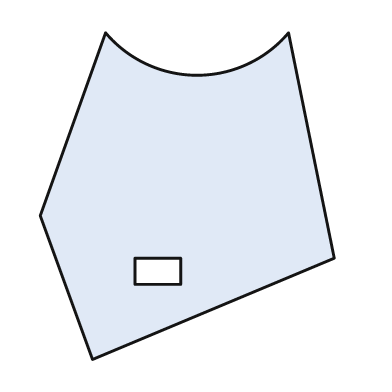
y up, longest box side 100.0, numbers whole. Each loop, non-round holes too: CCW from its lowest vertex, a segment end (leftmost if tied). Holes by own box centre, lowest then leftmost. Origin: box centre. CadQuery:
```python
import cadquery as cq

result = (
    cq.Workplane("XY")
    .moveTo(-29.0, -50.0)
    .lineTo(45.0, -19.0)
    .lineTo(31.0, 50.0)
    .threePointArc((3.0, 37.0), (-25.0, 50.0))
    .lineTo(-45.0, -6.0)
    .close()
    .moveTo(-16.0, -27.0)
    .lineTo(-2.0, -27.0)
    .lineTo(-2.0, -19.0)
    .lineTo(-16.0, -19.0)
    .close()
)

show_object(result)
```